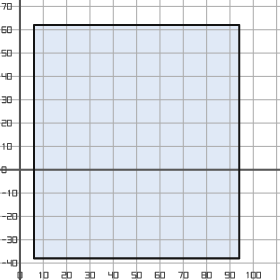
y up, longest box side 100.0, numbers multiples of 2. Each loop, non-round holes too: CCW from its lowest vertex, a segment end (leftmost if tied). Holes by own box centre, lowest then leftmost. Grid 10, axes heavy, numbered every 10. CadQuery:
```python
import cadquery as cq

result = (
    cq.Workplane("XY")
    .moveTo(6.0, -38.0)
    .lineTo(94.0, -38.0)
    .lineTo(94.0, 62.0)
    .lineTo(6.0, 62.0)
    .close()
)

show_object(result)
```